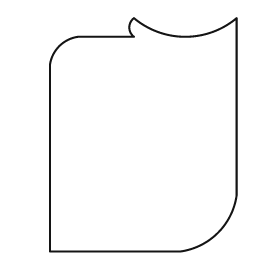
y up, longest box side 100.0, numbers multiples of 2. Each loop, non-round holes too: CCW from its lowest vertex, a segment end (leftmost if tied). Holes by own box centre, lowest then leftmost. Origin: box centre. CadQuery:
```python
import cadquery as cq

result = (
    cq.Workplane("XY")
    .moveTo(-40.0, -50.0)
    .lineTo(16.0, -50.0)
    .threePointArc((32.0, -42.0), (40.0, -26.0))
    .lineTo(40.0, 50.0)
    .threePointArc((18.0, 42.0), (-4.0, 50.0))
    .threePointArc((-6.0, 46.0), (-4.0, 42.0))
    .lineTo(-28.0, 42.0)
    .threePointArc((-36.0, 38.0), (-40.0, 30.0))
    .close()
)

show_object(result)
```